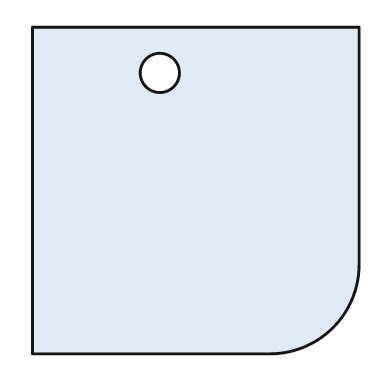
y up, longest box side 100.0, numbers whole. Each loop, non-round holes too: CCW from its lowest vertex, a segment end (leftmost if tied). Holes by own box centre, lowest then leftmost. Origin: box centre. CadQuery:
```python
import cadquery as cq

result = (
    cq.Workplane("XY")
    .moveTo(-50.0, -50.0)
    .lineTo(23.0, -50.0)
    .threePointArc((42.0, -42.0), (50.0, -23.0))
    .lineTo(50.0, 50.0)
    .lineTo(-50.0, 50.0)
    .close()
    .moveTo(-11.0, 36.0)
    .circle(6.0)
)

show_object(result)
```